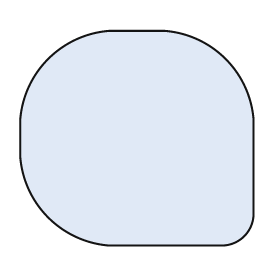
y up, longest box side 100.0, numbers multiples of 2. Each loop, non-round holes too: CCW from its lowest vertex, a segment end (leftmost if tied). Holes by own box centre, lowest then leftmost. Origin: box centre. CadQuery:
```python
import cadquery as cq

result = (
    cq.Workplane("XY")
    .moveTo(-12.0, -46.0)
    .lineTo(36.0, -46.0)
    .threePointArc((46.0, -42.0), (50.0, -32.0))
    .lineTo(50.0, 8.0)
    .threePointArc((38.0, 34.0), (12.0, 46.0))
    .lineTo(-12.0, 46.0)
    .threePointArc((-38.0, 34.0), (-50.0, 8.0))
    .lineTo(-50.0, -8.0)
    .threePointArc((-38.0, -34.0), (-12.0, -46.0))
    .close()
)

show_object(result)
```